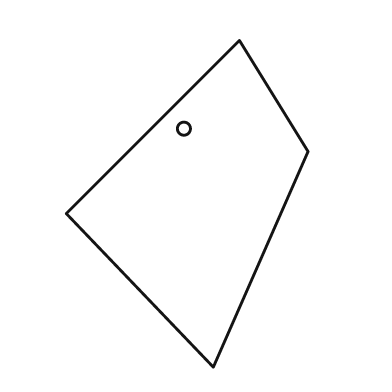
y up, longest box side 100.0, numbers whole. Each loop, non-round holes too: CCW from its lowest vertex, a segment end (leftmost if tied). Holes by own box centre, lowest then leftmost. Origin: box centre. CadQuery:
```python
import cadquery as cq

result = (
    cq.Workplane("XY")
    .moveTo(8.0, -50.0)
    .lineTo(37.0, 16.0)
    .lineTo(16.0, 50.0)
    .lineTo(-37.0, -3.0)
    .close()
    .moveTo(-1.0, 23.0)
    .circle(2.0)
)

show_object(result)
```